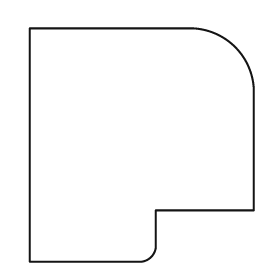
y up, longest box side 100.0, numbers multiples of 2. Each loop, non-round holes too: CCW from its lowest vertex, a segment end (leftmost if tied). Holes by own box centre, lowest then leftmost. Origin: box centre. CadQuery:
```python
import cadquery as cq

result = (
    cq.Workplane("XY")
    .moveTo(-48.0, -50.0)
    .lineTo(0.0, -50.0)
    .threePointArc((4.0, -48.0), (6.0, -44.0))
    .lineTo(6.0, -28.0)
    .lineTo(48.0, -28.0)
    .lineTo(48.0, 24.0)
    .threePointArc((40.0, 42.0), (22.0, 50.0))
    .lineTo(-48.0, 50.0)
    .close()
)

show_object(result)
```